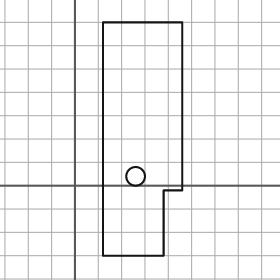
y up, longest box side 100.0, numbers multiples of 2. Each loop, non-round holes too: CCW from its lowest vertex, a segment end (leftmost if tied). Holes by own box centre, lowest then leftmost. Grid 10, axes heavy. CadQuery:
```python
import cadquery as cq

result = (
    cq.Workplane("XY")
    .moveTo(12.0, -30.0)
    .lineTo(38.0, -30.0)
    .lineTo(38.0, -2.0)
    .lineTo(46.0, -2.0)
    .lineTo(46.0, 70.0)
    .lineTo(12.0, 70.0)
    .close()
    .moveTo(26.0, 4.0)
    .circle(4.0)
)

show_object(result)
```